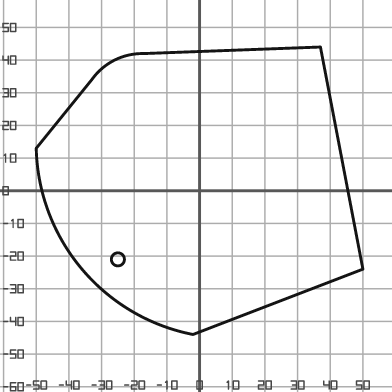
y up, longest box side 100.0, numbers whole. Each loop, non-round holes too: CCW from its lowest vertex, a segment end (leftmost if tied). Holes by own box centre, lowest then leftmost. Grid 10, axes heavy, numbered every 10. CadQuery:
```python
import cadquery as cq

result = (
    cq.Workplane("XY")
    .moveTo(-2.0, -44.0)
    .lineTo(50.0, -24.0)
    .lineTo(37.0, 44.0)
    .lineTo(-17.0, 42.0)
    .threePointArc((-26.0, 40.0), (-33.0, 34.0))
    .lineTo(-50.0, 13.0)
    .threePointArc((-36.0, -24.0), (-2.0, -44.0))
    .close()
    .moveTo(-25.0, -21.0)
    .circle(2.0)
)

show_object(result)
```